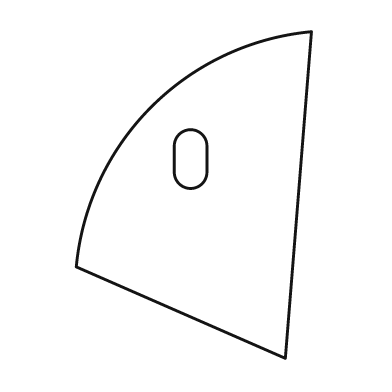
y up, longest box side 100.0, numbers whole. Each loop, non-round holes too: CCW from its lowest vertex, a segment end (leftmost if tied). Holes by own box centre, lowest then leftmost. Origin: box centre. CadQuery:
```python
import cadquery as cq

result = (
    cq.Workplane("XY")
    .moveTo(28.0, -50.0)
    .lineTo(36.0, 50.0)
    .threePointArc((-13.0, 27.0), (-36.0, -22.0))
    .close()
    .moveTo(-6.0, 7.0)
    .threePointArc((-1.0, 2.0), (4.0, 7.0))
    .lineTo(4.0, 15.0)
    .threePointArc((-1.0, 20.0), (-6.0, 15.0))
    .close()
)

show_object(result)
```